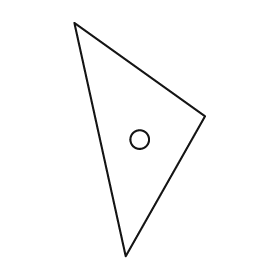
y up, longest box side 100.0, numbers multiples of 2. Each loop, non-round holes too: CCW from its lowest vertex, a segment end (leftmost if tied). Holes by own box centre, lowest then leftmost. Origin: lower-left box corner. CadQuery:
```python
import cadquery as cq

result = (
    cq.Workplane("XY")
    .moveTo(22.0, 0.0)
    .lineTo(56.0, 60.0)
    .lineTo(0.0, 100.0)
    .close()
    .moveTo(28.0, 50.0)
    .circle(4.0)
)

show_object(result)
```